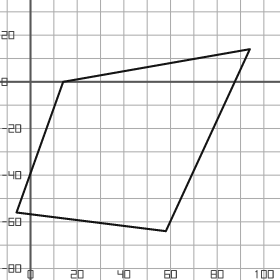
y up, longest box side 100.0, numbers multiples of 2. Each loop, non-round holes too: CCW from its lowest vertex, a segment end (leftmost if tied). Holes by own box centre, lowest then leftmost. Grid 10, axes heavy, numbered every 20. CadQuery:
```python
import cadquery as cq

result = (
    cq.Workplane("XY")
    .moveTo(58.0, -64.0)
    .lineTo(94.0, 14.0)
    .lineTo(14.0, 0.0)
    .lineTo(-6.0, -56.0)
    .close()
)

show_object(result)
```